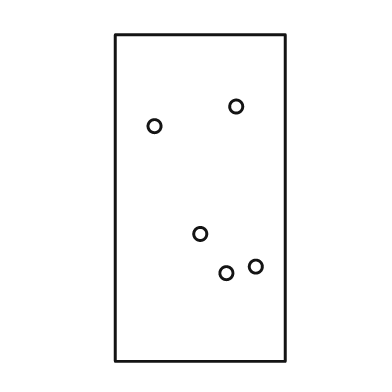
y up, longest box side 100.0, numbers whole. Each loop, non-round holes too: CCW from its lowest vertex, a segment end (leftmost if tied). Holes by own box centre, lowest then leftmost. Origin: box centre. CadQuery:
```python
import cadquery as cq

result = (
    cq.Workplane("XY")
    .moveTo(-26.0, -50.0)
    .lineTo(26.0, -50.0)
    .lineTo(26.0, 50.0)
    .lineTo(-26.0, 50.0)
    .close()
    .moveTo(8.0, -23.0)
    .circle(2.0)
    .moveTo(17.0, -21.0)
    .circle(2.0)
    .moveTo(0.0, -11.0)
    .circle(2.0)
    .moveTo(-14.0, 22.0)
    .circle(2.0)
    .moveTo(11.0, 28.0)
    .circle(2.0)
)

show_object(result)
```